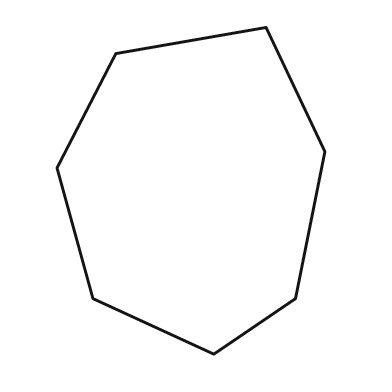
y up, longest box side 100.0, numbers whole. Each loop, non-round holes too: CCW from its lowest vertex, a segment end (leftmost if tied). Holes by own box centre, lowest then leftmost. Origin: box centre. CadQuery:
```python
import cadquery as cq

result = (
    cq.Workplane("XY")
    .moveTo(7.0, -50.0)
    .lineTo(32.0, -33.0)
    .lineTo(41.0, 12.0)
    .lineTo(23.0, 50.0)
    .lineTo(-23.0, 42.0)
    .lineTo(-41.0, 7.0)
    .lineTo(-30.0, -33.0)
    .close()
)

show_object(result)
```